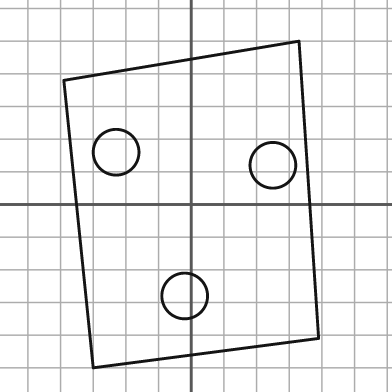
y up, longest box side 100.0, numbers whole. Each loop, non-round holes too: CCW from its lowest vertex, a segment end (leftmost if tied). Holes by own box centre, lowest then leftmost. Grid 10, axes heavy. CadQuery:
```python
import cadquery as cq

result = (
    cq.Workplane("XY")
    .moveTo(-30.0, -50.0)
    .lineTo(39.0, -41.0)
    .lineTo(33.0, 50.0)
    .lineTo(-39.0, 38.0)
    .close()
    .moveTo(-2.0, -28.0)
    .circle(7.0)
    .moveTo(25.0, 12.0)
    .circle(7.0)
    .moveTo(-23.0, 16.0)
    .circle(7.0)
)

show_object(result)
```